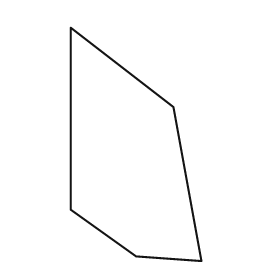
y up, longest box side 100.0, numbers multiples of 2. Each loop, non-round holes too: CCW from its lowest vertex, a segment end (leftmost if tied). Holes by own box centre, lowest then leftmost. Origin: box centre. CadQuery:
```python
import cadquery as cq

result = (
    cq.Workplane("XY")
    .moveTo(28.0, -50.0)
    .lineTo(16.0, 16.0)
    .lineTo(-28.0, 50.0)
    .lineTo(-28.0, -28.0)
    .lineTo(0.0, -48.0)
    .close()
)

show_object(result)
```